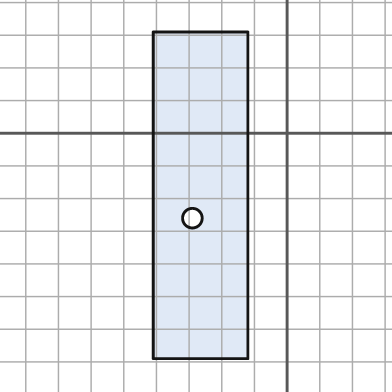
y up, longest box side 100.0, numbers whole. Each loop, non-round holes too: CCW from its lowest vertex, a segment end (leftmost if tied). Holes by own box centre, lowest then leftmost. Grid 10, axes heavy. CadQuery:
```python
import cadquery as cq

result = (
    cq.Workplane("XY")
    .moveTo(-41.0, -69.0)
    .lineTo(-12.0, -69.0)
    .lineTo(-12.0, 31.0)
    .lineTo(-41.0, 31.0)
    .close()
    .moveTo(-29.0, -26.0)
    .circle(3.0)
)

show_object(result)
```